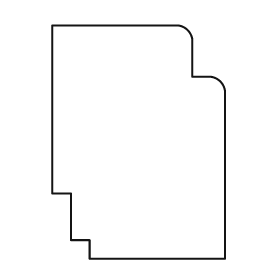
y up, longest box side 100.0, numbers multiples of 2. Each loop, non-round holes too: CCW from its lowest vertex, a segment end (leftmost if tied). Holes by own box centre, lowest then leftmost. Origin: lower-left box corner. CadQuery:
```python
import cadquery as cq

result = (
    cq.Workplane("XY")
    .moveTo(16.0, 0.0)
    .lineTo(74.0, 0.0)
    .lineTo(74.0, 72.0)
    .threePointArc((72.0, 76.0), (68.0, 78.0))
    .lineTo(60.0, 78.0)
    .lineTo(60.0, 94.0)
    .threePointArc((58.0, 98.0), (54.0, 100.0))
    .lineTo(0.0, 100.0)
    .lineTo(0.0, 28.0)
    .lineTo(8.0, 28.0)
    .lineTo(8.0, 8.0)
    .lineTo(16.0, 8.0)
    .close()
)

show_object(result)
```